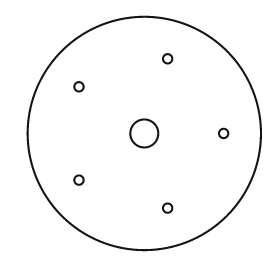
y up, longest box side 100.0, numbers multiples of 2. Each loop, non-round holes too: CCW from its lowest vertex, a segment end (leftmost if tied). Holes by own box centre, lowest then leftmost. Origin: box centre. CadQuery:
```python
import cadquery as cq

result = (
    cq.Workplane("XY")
    .moveTo(0.0, 0.0)
    .circle(50.0)
    .moveTo(10.0, -32.0)
    .circle(2.0)
    .moveTo(-28.0, -20.0)
    .circle(2.0)
    .moveTo(0.0, 0.0)
    .circle(6.0)
    .moveTo(34.0, 0.0)
    .circle(2.0)
    .moveTo(-28.0, 20.0)
    .circle(2.0)
    .moveTo(10.0, 32.0)
    .circle(2.0)
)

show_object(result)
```